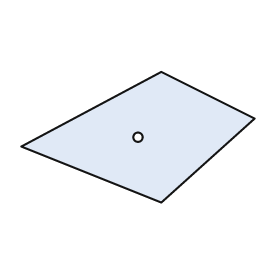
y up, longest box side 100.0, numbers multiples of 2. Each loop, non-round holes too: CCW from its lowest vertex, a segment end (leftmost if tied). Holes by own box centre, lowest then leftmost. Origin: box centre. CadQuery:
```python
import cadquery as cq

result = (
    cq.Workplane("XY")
    .moveTo(10.0, -28.0)
    .lineTo(50.0, 8.0)
    .lineTo(10.0, 28.0)
    .lineTo(-50.0, -4.0)
    .close()
    .moveTo(0.0, 0.0)
    .circle(2.0)
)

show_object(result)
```